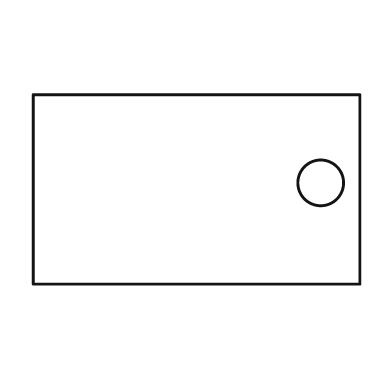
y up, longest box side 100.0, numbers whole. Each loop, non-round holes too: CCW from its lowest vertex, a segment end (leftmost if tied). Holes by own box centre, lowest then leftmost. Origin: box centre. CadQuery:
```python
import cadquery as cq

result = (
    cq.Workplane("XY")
    .moveTo(-50.0, -29.0)
    .lineTo(50.0, -29.0)
    .lineTo(50.0, 29.0)
    .lineTo(-50.0, 29.0)
    .close()
    .moveTo(38.0, 2.0)
    .circle(7.0)
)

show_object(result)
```